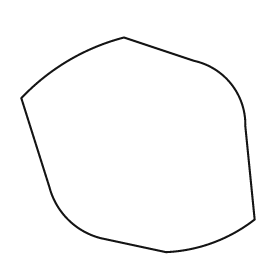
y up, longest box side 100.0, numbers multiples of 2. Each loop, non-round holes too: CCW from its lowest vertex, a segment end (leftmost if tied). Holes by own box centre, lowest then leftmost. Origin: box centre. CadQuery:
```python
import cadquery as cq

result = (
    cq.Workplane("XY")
    .moveTo(12.0, -46.0)
    .threePointArc((32.0, -42.0), (50.0, -32.0))
    .lineTo(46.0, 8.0)
    .threePointArc((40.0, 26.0), (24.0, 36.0))
    .lineTo(-6.0, 46.0)
    .threePointArc((-30.0, 36.0), (-50.0, 20.0))
    .lineTo(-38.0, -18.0)
    .threePointArc((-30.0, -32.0), (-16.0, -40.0))
    .close()
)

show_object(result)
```